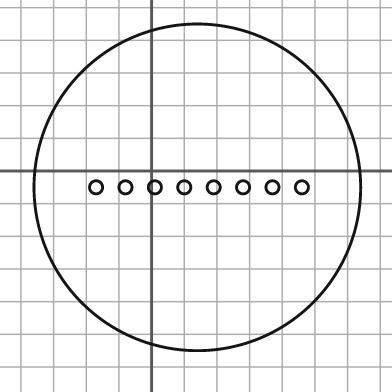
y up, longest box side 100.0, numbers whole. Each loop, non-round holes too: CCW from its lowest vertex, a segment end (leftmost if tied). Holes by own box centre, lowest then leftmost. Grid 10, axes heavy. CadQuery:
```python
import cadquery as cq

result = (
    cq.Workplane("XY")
    .moveTo(14.0, -5.0)
    .circle(50.0)
    .moveTo(-17.0, -5.0)
    .circle(2.0)
    .moveTo(-8.0, -5.0)
    .circle(2.0)
    .moveTo(1.0, -5.0)
    .circle(2.0)
    .moveTo(10.0, -5.0)
    .circle(2.0)
    .moveTo(19.0, -5.0)
    .circle(2.0)
    .moveTo(28.0, -5.0)
    .circle(2.0)
    .moveTo(37.0, -5.0)
    .circle(2.0)
    .moveTo(46.0, -5.0)
    .circle(2.0)
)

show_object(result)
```